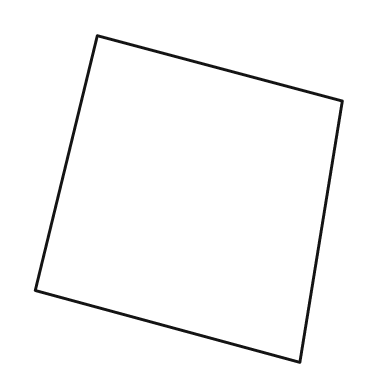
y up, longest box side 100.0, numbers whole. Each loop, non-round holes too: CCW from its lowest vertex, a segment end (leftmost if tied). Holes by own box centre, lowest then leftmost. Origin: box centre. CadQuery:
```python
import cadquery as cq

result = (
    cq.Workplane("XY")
    .moveTo(34.0, -50.0)
    .lineTo(47.0, 30.0)
    .lineTo(-28.0, 50.0)
    .lineTo(-47.0, -28.0)
    .close()
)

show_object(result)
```